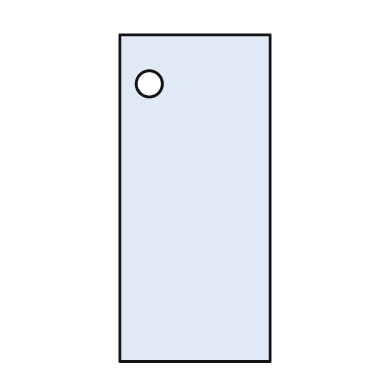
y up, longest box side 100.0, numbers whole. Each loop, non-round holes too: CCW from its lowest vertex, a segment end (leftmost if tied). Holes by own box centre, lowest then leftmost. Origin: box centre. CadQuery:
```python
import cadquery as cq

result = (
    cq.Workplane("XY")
    .moveTo(-23.0, -50.0)
    .lineTo(23.0, -50.0)
    .lineTo(23.0, 50.0)
    .lineTo(-23.0, 50.0)
    .close()
    .moveTo(-14.0, 35.0)
    .circle(4.0)
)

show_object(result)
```